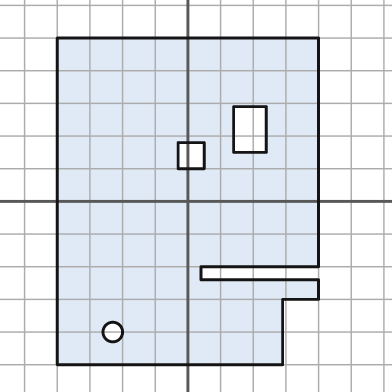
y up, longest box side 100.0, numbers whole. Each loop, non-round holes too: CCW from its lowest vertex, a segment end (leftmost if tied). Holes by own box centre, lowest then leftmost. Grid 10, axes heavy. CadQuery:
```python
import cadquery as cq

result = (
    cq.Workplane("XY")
    .moveTo(-40.0, -50.0)
    .lineTo(29.0, -50.0)
    .lineTo(29.0, -30.0)
    .lineTo(40.0, -30.0)
    .lineTo(40.0, -24.0)
    .lineTo(4.0, -24.0)
    .lineTo(4.0, -20.0)
    .lineTo(40.0, -20.0)
    .lineTo(40.0, 50.0)
    .lineTo(-40.0, 50.0)
    .close()
    .moveTo(-23.0, -40.0)
    .circle(3.0)
    .moveTo(-3.0, 10.0)
    .lineTo(5.0, 10.0)
    .lineTo(5.0, 18.0)
    .lineTo(-3.0, 18.0)
    .close()
    .moveTo(14.0, 15.0)
    .lineTo(24.0, 15.0)
    .lineTo(24.0, 29.0)
    .lineTo(14.0, 29.0)
    .close()
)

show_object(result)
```